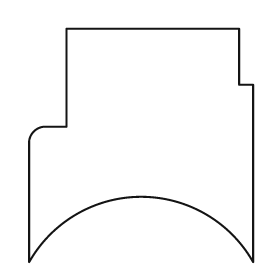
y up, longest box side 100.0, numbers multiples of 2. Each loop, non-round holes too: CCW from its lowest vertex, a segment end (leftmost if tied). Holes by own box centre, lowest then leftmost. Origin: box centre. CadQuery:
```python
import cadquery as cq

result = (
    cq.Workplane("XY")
    .moveTo(-48.0, -50.0)
    .threePointArc((0.0, -22.0), (48.0, -50.0))
    .lineTo(48.0, 26.0)
    .lineTo(42.0, 26.0)
    .lineTo(42.0, 50.0)
    .lineTo(-32.0, 50.0)
    .lineTo(-32.0, 8.0)
    .lineTo(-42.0, 8.0)
    .threePointArc((-46.0, 6.0), (-48.0, 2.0))
    .close()
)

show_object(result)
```